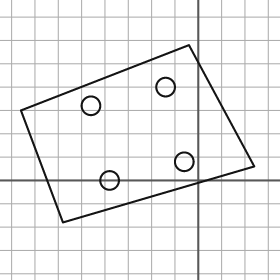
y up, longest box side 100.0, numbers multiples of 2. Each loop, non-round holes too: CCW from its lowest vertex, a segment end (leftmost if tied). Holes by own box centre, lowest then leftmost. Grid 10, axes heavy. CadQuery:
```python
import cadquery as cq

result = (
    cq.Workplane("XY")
    .moveTo(-58.0, -18.0)
    .lineTo(24.0, 6.0)
    .lineTo(-4.0, 58.0)
    .lineTo(-76.0, 30.0)
    .close()
    .moveTo(-38.0, 0.0)
    .circle(4.0)
    .moveTo(-6.0, 8.0)
    .circle(4.0)
    .moveTo(-46.0, 32.0)
    .circle(4.0)
    .moveTo(-14.0, 40.0)
    .circle(4.0)
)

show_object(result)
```